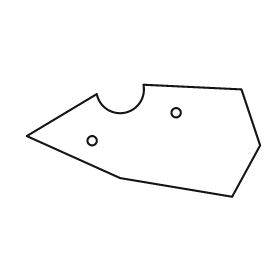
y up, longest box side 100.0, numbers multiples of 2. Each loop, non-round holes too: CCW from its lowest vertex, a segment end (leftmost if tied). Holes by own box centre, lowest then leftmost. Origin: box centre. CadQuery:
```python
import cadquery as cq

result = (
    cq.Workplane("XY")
    .moveTo(38.0, -24.0)
    .lineTo(50.0, -2.0)
    .lineTo(42.0, 22.0)
    .lineTo(0.0, 24.0)
    .threePointArc((-8.0, 12.0), (-20.0, 20.0))
    .lineTo(-50.0, 2.0)
    .lineTo(-10.0, -16.0)
    .close()
    .moveTo(-22.0, 0.0)
    .circle(2.0)
    .moveTo(14.0, 12.0)
    .circle(2.0)
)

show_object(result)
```